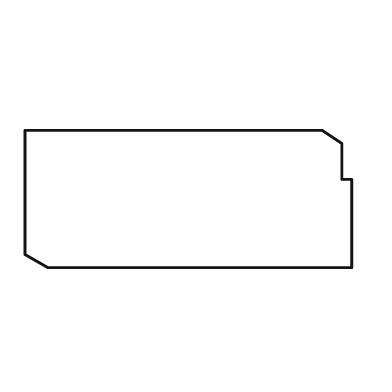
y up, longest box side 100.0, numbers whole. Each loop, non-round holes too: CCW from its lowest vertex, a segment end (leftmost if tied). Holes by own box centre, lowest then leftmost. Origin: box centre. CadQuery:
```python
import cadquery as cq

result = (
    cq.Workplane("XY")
    .moveTo(-43.0, -21.0)
    .lineTo(50.0, -21.0)
    .lineTo(50.0, 6.0)
    .lineTo(47.0, 6.0)
    .lineTo(47.0, 17.0)
    .lineTo(41.0, 21.0)
    .lineTo(-50.0, 21.0)
    .lineTo(-50.0, -17.0)
    .close()
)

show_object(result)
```